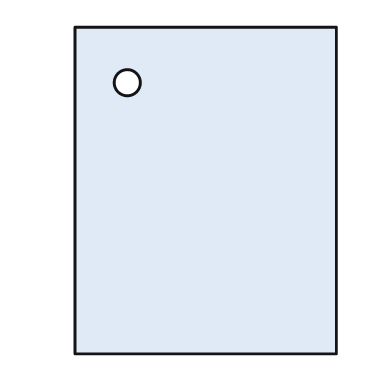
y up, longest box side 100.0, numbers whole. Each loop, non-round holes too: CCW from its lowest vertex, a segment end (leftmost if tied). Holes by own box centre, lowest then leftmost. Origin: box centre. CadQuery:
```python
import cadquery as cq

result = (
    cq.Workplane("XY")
    .moveTo(-40.0, -50.0)
    .lineTo(40.0, -50.0)
    .lineTo(40.0, 50.0)
    .lineTo(-40.0, 50.0)
    .close()
    .moveTo(-24.0, 33.0)
    .circle(4.0)
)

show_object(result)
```